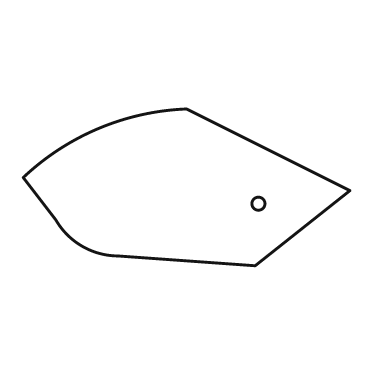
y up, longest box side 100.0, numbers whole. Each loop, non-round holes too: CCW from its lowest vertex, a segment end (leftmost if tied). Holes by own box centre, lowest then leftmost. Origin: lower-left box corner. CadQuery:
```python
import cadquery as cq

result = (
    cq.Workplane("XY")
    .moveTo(71.0, 0.0)
    .lineTo(100.0, 23.0)
    .lineTo(50.0, 48.0)
    .threePointArc((23.0, 42.0), (0.0, 27.0))
    .lineTo(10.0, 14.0)
    .threePointArc((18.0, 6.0), (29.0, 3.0))
    .close()
    .moveTo(72.0, 19.0)
    .circle(2.0)
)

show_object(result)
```